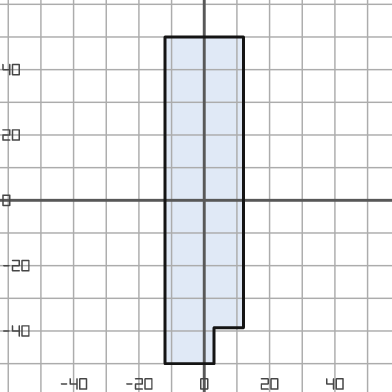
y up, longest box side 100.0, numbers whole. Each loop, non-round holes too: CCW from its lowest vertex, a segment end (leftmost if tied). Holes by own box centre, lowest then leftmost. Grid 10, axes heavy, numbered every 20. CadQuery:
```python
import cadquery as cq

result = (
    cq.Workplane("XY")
    .moveTo(-12.0, -50.0)
    .lineTo(3.0, -50.0)
    .lineTo(3.0, -39.0)
    .lineTo(12.0, -39.0)
    .lineTo(12.0, 50.0)
    .lineTo(-12.0, 50.0)
    .close()
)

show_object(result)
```